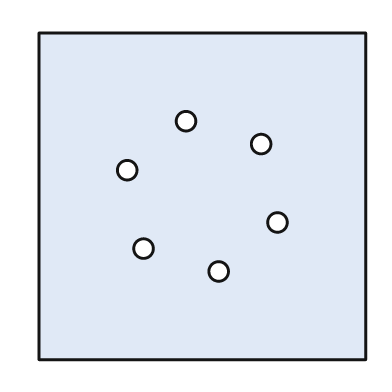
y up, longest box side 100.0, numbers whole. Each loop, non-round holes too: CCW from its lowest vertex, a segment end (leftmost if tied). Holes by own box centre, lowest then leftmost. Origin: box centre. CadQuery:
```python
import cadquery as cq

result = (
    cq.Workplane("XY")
    .moveTo(-50.0, -50.0)
    .lineTo(50.0, -50.0)
    .lineTo(50.0, 50.0)
    .lineTo(-50.0, 50.0)
    .close()
    .moveTo(5.0, -23.0)
    .circle(3.0)
    .moveTo(-18.0, -16.0)
    .circle(3.0)
    .moveTo(23.0, -8.0)
    .circle(3.0)
    .moveTo(-23.0, 8.0)
    .circle(3.0)
    .moveTo(18.0, 16.0)
    .circle(3.0)
    .moveTo(-5.0, 23.0)
    .circle(3.0)
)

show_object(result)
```